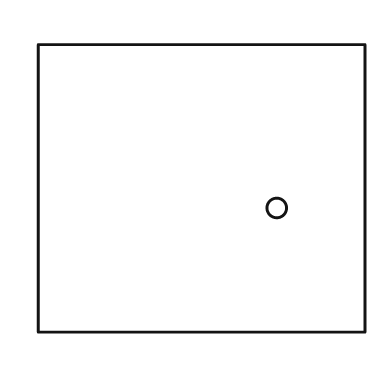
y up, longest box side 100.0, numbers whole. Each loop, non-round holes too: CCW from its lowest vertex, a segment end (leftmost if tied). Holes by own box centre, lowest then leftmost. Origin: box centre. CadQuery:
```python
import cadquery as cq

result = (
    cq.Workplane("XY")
    .moveTo(-50.0, -44.0)
    .lineTo(50.0, -44.0)
    .lineTo(50.0, 44.0)
    .lineTo(-50.0, 44.0)
    .close()
    .moveTo(23.0, -6.0)
    .circle(3.0)
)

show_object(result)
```